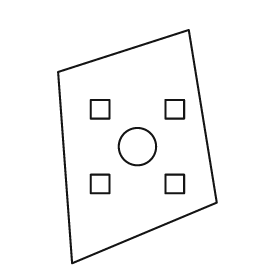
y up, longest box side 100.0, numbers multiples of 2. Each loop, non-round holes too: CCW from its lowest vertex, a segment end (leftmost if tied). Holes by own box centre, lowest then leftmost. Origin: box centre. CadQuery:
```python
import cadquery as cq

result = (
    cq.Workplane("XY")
    .moveTo(-28.0, -50.0)
    .lineTo(34.0, -24.0)
    .lineTo(22.0, 50.0)
    .lineTo(-34.0, 32.0)
    .close()
    .moveTo(-20.0, -20.0)
    .lineTo(-12.0, -20.0)
    .lineTo(-12.0, -12.0)
    .lineTo(-20.0, -12.0)
    .close()
    .moveTo(12.0, -20.0)
    .lineTo(20.0, -20.0)
    .lineTo(20.0, -12.0)
    .lineTo(12.0, -12.0)
    .close()
    .moveTo(0.0, 0.0)
    .circle(8.0)
    .moveTo(-20.0, 12.0)
    .lineTo(-12.0, 12.0)
    .lineTo(-12.0, 20.0)
    .lineTo(-20.0, 20.0)
    .close()
    .moveTo(12.0, 12.0)
    .lineTo(20.0, 12.0)
    .lineTo(20.0, 20.0)
    .lineTo(12.0, 20.0)
    .close()
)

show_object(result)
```